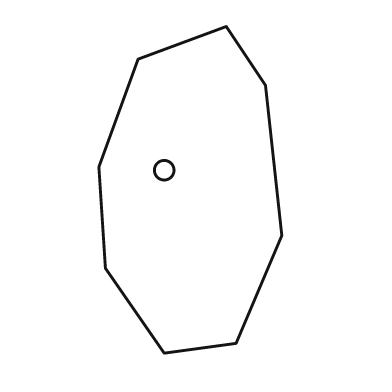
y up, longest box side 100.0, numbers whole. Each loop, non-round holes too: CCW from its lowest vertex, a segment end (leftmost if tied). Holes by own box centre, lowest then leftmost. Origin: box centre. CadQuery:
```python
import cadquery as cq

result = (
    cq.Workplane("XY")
    .moveTo(-8.0, -50.0)
    .lineTo(14.0, -47.0)
    .lineTo(28.0, -14.0)
    .lineTo(23.0, 32.0)
    .lineTo(11.0, 50.0)
    .lineTo(-16.0, 40.0)
    .lineTo(-28.0, 7.0)
    .lineTo(-26.0, -24.0)
    .close()
    .moveTo(-8.0, 6.0)
    .circle(3.0)
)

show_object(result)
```